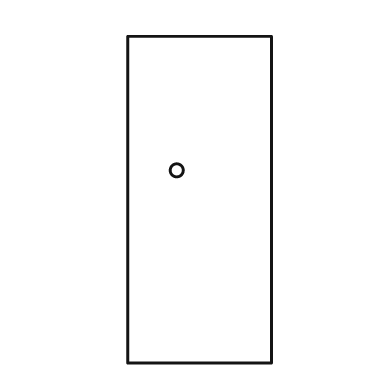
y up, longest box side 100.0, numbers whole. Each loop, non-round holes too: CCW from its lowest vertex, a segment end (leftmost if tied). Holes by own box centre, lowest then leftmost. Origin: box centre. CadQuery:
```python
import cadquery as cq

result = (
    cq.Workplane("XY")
    .moveTo(-22.0, -50.0)
    .lineTo(22.0, -50.0)
    .lineTo(22.0, 50.0)
    .lineTo(-22.0, 50.0)
    .close()
    .moveTo(-7.0, 9.0)
    .circle(2.0)
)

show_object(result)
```